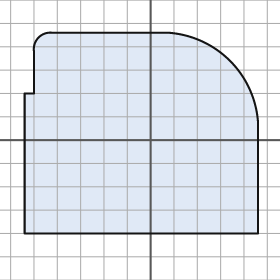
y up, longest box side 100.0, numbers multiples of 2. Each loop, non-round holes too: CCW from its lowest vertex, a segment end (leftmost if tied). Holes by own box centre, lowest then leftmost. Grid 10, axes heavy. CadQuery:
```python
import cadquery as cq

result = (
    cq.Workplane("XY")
    .moveTo(-54.0, -40.0)
    .lineTo(46.0, -40.0)
    .lineTo(46.0, 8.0)
    .threePointArc((34.0, 34.0), (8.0, 46.0))
    .lineTo(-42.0, 46.0)
    .threePointArc((-48.0, 44.0), (-50.0, 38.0))
    .lineTo(-50.0, 20.0)
    .lineTo(-54.0, 20.0)
    .close()
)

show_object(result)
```